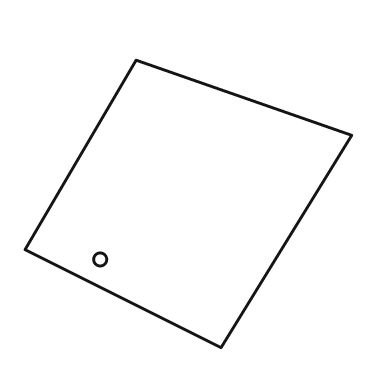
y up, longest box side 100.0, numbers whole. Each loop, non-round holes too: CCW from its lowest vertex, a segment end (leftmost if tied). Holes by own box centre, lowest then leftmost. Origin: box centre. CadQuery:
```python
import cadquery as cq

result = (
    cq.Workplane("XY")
    .moveTo(10.0, -44.0)
    .lineTo(50.0, 21.0)
    .lineTo(-16.0, 44.0)
    .lineTo(-50.0, -14.0)
    .close()
    .moveTo(-27.0, -17.0)
    .circle(2.0)
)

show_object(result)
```